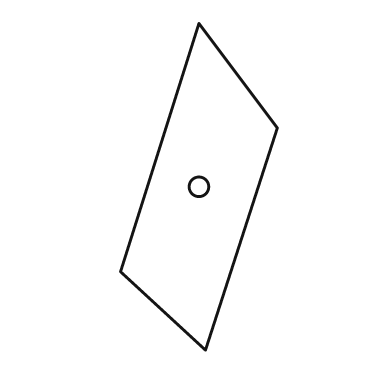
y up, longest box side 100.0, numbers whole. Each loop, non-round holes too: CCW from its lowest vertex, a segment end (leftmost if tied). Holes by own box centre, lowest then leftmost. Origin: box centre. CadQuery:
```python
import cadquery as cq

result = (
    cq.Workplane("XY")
    .moveTo(2.0, -50.0)
    .lineTo(24.0, 18.0)
    .lineTo(0.0, 50.0)
    .lineTo(-24.0, -26.0)
    .close()
    .moveTo(0.0, 0.0)
    .circle(3.0)
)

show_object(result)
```